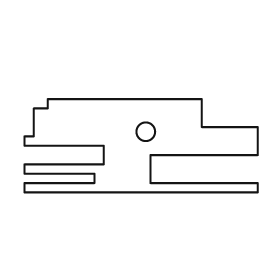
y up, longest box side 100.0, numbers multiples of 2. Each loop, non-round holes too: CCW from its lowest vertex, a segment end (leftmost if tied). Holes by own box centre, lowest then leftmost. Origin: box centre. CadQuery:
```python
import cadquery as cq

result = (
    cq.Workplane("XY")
    .moveTo(-50.0, -20.0)
    .lineTo(50.0, -20.0)
    .lineTo(50.0, -16.0)
    .lineTo(4.0, -16.0)
    .lineTo(4.0, -4.0)
    .lineTo(50.0, -4.0)
    .lineTo(50.0, 8.0)
    .lineTo(26.0, 8.0)
    .lineTo(26.0, 20.0)
    .lineTo(-40.0, 20.0)
    .lineTo(-40.0, 16.0)
    .lineTo(-46.0, 16.0)
    .lineTo(-46.0, 4.0)
    .lineTo(-50.0, 4.0)
    .lineTo(-50.0, 0.0)
    .lineTo(-16.0, 0.0)
    .lineTo(-16.0, -8.0)
    .lineTo(-50.0, -8.0)
    .lineTo(-50.0, -12.0)
    .lineTo(-20.0, -12.0)
    .lineTo(-20.0, -16.0)
    .lineTo(-50.0, -16.0)
    .close()
    .moveTo(2.0, 6.0)
    .circle(4.0)
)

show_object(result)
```